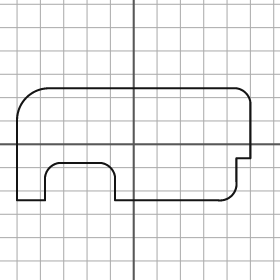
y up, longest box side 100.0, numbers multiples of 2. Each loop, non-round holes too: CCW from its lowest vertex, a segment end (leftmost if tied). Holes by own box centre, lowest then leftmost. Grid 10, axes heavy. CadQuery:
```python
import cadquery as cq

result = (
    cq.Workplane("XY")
    .moveTo(-50.0, -24.0)
    .lineTo(-38.0, -24.0)
    .lineTo(-38.0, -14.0)
    .threePointArc((-36.0, -10.0), (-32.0, -8.0))
    .lineTo(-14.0, -8.0)
    .threePointArc((-10.0, -10.0), (-8.0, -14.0))
    .lineTo(-8.0, -24.0)
    .lineTo(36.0, -24.0)
    .threePointArc((42.0, -22.0), (44.0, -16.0))
    .lineTo(44.0, -6.0)
    .lineTo(50.0, -6.0)
    .lineTo(50.0, 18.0)
    .threePointArc((48.0, 22.0), (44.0, 24.0))
    .lineTo(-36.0, 24.0)
    .threePointArc((-46.0, 20.0), (-50.0, 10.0))
    .close()
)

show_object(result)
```